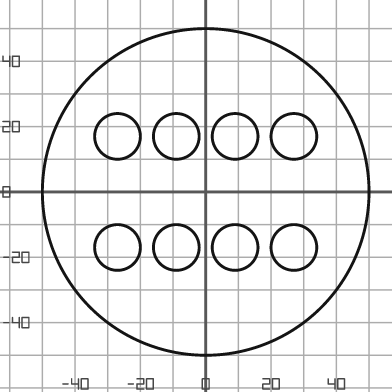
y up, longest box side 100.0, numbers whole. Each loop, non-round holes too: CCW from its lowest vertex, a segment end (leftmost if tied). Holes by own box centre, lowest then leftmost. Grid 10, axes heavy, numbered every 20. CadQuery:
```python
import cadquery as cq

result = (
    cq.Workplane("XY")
    .moveTo(0.0, 0.0)
    .circle(50.0)
    .moveTo(-27.0, -17.0)
    .circle(7.0)
    .moveTo(-9.0, -17.0)
    .circle(7.0)
    .moveTo(9.0, -17.0)
    .circle(7.0)
    .moveTo(27.0, -17.0)
    .circle(7.0)
    .moveTo(-27.0, 17.0)
    .circle(7.0)
    .moveTo(-9.0, 17.0)
    .circle(7.0)
    .moveTo(9.0, 17.0)
    .circle(7.0)
    .moveTo(27.0, 17.0)
    .circle(7.0)
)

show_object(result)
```